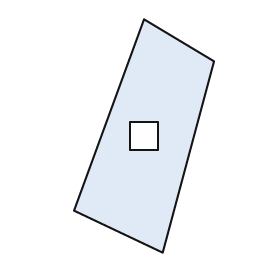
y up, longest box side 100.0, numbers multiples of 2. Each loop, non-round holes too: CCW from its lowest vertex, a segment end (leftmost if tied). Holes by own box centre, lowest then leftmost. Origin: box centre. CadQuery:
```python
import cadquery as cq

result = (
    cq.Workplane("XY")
    .moveTo(8.0, -50.0)
    .lineTo(30.0, 32.0)
    .lineTo(0.0, 50.0)
    .lineTo(-30.0, -32.0)
    .close()
    .moveTo(-6.0, -6.0)
    .lineTo(6.0, -6.0)
    .lineTo(6.0, 6.0)
    .lineTo(-6.0, 6.0)
    .close()
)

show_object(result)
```